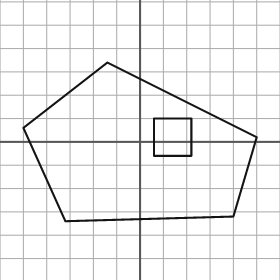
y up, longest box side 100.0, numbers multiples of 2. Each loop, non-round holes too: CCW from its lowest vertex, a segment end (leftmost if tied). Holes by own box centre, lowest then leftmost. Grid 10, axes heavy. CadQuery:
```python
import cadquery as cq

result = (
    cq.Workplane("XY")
    .moveTo(-32.0, -34.0)
    .lineTo(40.0, -32.0)
    .lineTo(50.0, 2.0)
    .lineTo(-14.0, 34.0)
    .lineTo(-50.0, 6.0)
    .close()
    .moveTo(6.0, -6.0)
    .lineTo(22.0, -6.0)
    .lineTo(22.0, 10.0)
    .lineTo(6.0, 10.0)
    .close()
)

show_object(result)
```